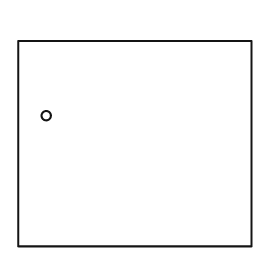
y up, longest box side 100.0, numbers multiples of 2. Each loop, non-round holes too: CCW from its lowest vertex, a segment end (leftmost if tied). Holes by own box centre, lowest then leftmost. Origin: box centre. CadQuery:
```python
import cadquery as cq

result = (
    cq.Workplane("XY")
    .moveTo(-50.0, -44.0)
    .lineTo(50.0, -44.0)
    .lineTo(50.0, 44.0)
    .lineTo(-50.0, 44.0)
    .close()
    .moveTo(-38.0, 12.0)
    .circle(2.0)
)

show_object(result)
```